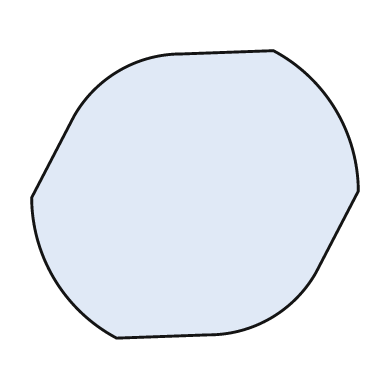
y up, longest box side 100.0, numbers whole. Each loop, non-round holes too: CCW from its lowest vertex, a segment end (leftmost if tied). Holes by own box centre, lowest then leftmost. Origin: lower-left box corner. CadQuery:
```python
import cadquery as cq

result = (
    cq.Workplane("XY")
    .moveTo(26.0, 0.0)
    .lineTo(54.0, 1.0)
    .threePointArc((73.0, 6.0), (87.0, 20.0))
    .lineTo(100.0, 45.0)
    .threePointArc((93.0, 70.0), (74.0, 88.0))
    .lineTo(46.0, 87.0)
    .threePointArc((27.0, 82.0), (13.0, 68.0))
    .lineTo(0.0, 43.0)
    .threePointArc((7.0, 18.0), (26.0, 0.0))
    .close()
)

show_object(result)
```